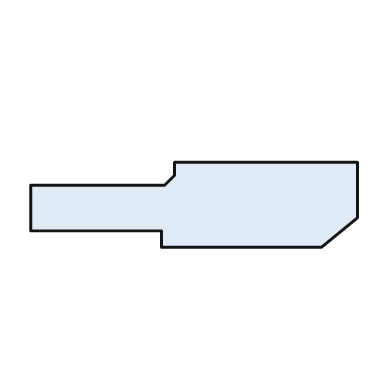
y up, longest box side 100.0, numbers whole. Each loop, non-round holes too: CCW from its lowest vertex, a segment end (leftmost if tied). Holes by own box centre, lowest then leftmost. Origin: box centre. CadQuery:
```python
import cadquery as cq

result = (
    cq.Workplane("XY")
    .moveTo(-10.0, -13.0)
    .lineTo(39.0, -13.0)
    .lineTo(50.0, -4.0)
    .lineTo(50.0, 13.0)
    .lineTo(-6.0, 13.0)
    .lineTo(-6.0, 9.0)
    .lineTo(-9.0, 6.0)
    .lineTo(-50.0, 6.0)
    .lineTo(-50.0, -8.0)
    .lineTo(-10.0, -8.0)
    .close()
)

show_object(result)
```